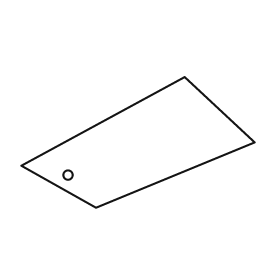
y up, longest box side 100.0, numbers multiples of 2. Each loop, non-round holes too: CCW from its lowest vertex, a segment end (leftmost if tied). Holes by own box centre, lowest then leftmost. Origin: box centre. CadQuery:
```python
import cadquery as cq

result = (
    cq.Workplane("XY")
    .moveTo(-18.0, -28.0)
    .lineTo(50.0, 0.0)
    .lineTo(20.0, 28.0)
    .lineTo(-50.0, -10.0)
    .close()
    .moveTo(-30.0, -14.0)
    .circle(2.0)
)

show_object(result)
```